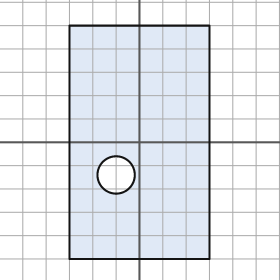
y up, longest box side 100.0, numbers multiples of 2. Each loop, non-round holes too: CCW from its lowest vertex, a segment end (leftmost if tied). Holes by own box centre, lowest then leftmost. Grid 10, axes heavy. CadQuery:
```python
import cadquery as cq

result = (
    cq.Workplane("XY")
    .moveTo(-30.0, -50.0)
    .lineTo(30.0, -50.0)
    .lineTo(30.0, 50.0)
    .lineTo(-30.0, 50.0)
    .close()
    .moveTo(-10.0, -14.0)
    .circle(8.0)
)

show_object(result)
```